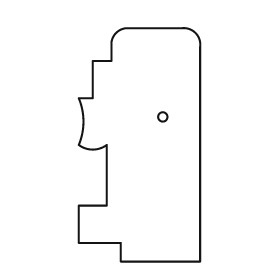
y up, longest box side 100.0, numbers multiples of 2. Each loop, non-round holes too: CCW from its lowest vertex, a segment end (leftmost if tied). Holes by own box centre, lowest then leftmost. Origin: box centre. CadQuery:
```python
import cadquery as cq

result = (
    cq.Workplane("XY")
    .moveTo(-8.0, -50.0)
    .lineTo(26.0, -50.0)
    .lineTo(26.0, 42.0)
    .threePointArc((24.0, 48.0), (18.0, 50.0))
    .lineTo(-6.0, 50.0)
    .threePointArc((-10.0, 48.0), (-12.0, 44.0))
    .lineTo(-12.0, 36.0)
    .lineTo(-20.0, 36.0)
    .lineTo(-20.0, 20.0)
    .lineTo(-26.0, 20.0)
    .threePointArc((-24.0, 10.0), (-26.0, 0.0))
    .threePointArc((-20.0, -2.0), (-14.0, 0.0))
    .lineTo(-14.0, -26.0)
    .lineTo(-26.0, -26.0)
    .lineTo(-26.0, -42.0)
    .lineTo(-8.0, -42.0)
    .close()
    .moveTo(10.0, 12.0)
    .circle(2.0)
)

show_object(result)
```